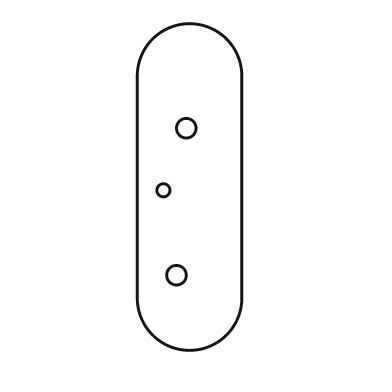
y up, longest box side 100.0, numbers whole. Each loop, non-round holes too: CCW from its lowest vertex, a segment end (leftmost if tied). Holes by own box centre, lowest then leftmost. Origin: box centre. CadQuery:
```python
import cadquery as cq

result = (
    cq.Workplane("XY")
    .moveTo(-16.0, -34.0)
    .threePointArc((0.0, -50.0), (16.0, -34.0))
    .lineTo(16.0, 34.0)
    .threePointArc((0.0, 50.0), (-16.0, 34.0))
    .close()
    .moveTo(-4.0, -27.0)
    .circle(3.0)
    .moveTo(-8.0, -1.0)
    .circle(2.0)
    .moveTo(-1.0, 18.0)
    .circle(3.0)
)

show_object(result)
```